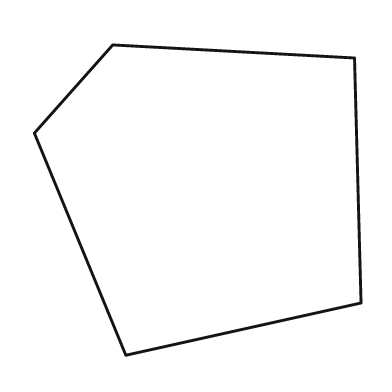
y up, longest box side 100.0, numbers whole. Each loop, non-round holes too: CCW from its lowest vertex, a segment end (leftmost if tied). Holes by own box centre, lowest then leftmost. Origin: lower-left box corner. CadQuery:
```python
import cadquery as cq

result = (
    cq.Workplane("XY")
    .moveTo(28.0, 0.0)
    .lineTo(100.0, 16.0)
    .lineTo(98.0, 91.0)
    .lineTo(24.0, 95.0)
    .lineTo(0.0, 68.0)
    .close()
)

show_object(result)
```